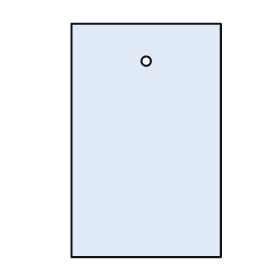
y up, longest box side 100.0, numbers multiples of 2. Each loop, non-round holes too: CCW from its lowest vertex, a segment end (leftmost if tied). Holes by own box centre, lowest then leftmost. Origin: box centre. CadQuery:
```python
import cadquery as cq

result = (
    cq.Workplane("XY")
    .moveTo(-32.0, -50.0)
    .lineTo(32.0, -50.0)
    .lineTo(32.0, 50.0)
    .lineTo(-32.0, 50.0)
    .close()
    .moveTo(0.0, 34.0)
    .circle(2.0)
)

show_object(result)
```